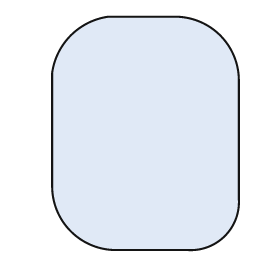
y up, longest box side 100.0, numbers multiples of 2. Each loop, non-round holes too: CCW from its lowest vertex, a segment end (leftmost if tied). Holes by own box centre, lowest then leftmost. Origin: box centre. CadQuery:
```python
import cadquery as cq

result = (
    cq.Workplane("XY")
    .moveTo(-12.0, -50.0)
    .lineTo(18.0, -50.0)
    .threePointArc((34.0, -44.0), (40.0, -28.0))
    .lineTo(40.0, 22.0)
    .threePointArc((32.0, 42.0), (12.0, 50.0))
    .lineTo(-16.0, 50.0)
    .threePointArc((-32.0, 42.0), (-40.0, 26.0))
    .lineTo(-40.0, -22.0)
    .threePointArc((-32.0, -42.0), (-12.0, -50.0))
    .close()
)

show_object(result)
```